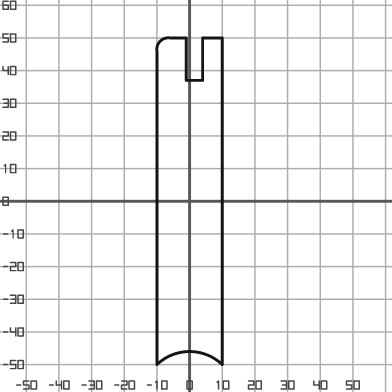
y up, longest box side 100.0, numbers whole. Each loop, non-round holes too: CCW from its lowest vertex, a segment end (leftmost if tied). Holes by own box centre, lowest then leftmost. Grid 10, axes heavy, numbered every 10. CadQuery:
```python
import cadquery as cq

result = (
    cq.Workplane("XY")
    .moveTo(-10.0, -50.0)
    .threePointArc((0.0, -46.0), (10.0, -50.0))
    .lineTo(10.0, 50.0)
    .lineTo(4.0, 50.0)
    .lineTo(4.0, 37.0)
    .lineTo(-1.0, 37.0)
    .lineTo(-1.0, 50.0)
    .lineTo(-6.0, 50.0)
    .threePointArc((-9.0, 49.0), (-10.0, 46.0))
    .close()
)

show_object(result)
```